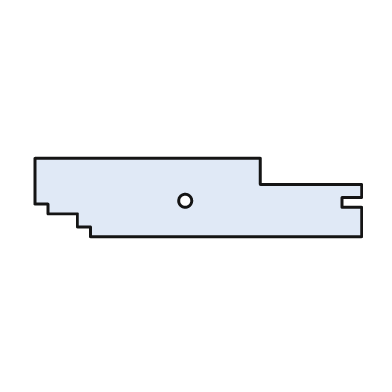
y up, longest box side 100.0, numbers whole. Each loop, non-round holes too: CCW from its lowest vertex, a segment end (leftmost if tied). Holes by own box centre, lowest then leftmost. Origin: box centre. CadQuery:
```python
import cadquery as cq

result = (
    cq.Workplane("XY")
    .moveTo(-33.0, -12.0)
    .lineTo(50.0, -12.0)
    .lineTo(50.0, -3.0)
    .lineTo(44.0, -3.0)
    .lineTo(44.0, 0.0)
    .lineTo(50.0, 0.0)
    .lineTo(50.0, 4.0)
    .lineTo(19.0, 4.0)
    .lineTo(19.0, 12.0)
    .lineTo(-50.0, 12.0)
    .lineTo(-50.0, -2.0)
    .lineTo(-46.0, -2.0)
    .lineTo(-46.0, -5.0)
    .lineTo(-37.0, -5.0)
    .lineTo(-37.0, -9.0)
    .lineTo(-33.0, -9.0)
    .close()
    .moveTo(-4.0, -1.0)
    .circle(2.0)
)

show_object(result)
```